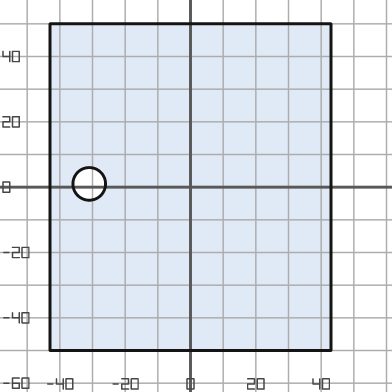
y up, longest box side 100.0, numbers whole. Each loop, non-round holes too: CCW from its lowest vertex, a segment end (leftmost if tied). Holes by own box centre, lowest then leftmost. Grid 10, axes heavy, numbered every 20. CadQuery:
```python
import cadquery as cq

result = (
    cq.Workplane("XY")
    .moveTo(-43.0, -50.0)
    .lineTo(43.0, -50.0)
    .lineTo(43.0, 50.0)
    .lineTo(-43.0, 50.0)
    .close()
    .moveTo(-31.0, 1.0)
    .circle(5.0)
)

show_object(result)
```